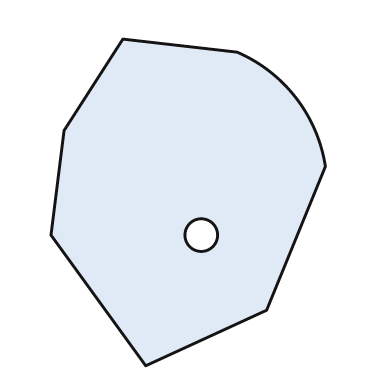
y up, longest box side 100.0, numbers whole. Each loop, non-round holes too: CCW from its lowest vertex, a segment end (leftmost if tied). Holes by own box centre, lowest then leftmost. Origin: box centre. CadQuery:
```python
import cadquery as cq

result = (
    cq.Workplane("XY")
    .moveTo(-13.0, -50.0)
    .lineTo(24.0, -33.0)
    .lineTo(42.0, 11.0)
    .threePointArc((33.0, 32.0), (15.0, 46.0))
    .lineTo(-20.0, 50.0)
    .lineTo(-38.0, 22.0)
    .lineTo(-42.0, -10.0)
    .close()
    .moveTo(4.0, -10.0)
    .circle(5.0)
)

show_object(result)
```